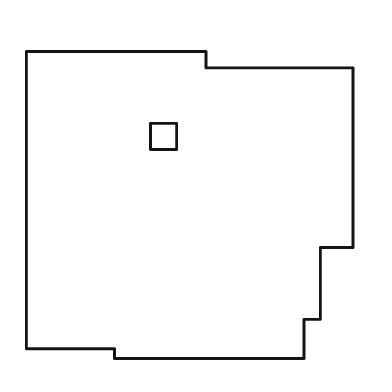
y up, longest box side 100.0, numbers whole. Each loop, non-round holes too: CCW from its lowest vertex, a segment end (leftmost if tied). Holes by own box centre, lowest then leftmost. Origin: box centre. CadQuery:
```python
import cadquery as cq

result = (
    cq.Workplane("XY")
    .moveTo(-23.0, -47.0)
    .lineTo(35.0, -47.0)
    .lineTo(35.0, -35.0)
    .lineTo(40.0, -35.0)
    .lineTo(40.0, -13.0)
    .lineTo(50.0, -13.0)
    .lineTo(50.0, 42.0)
    .lineTo(5.0, 42.0)
    .lineTo(5.0, 47.0)
    .lineTo(-50.0, 47.0)
    .lineTo(-50.0, -44.0)
    .lineTo(-23.0, -44.0)
    .close()
    .moveTo(-12.0, 17.0)
    .lineTo(-4.0, 17.0)
    .lineTo(-4.0, 25.0)
    .lineTo(-12.0, 25.0)
    .close()
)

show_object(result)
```